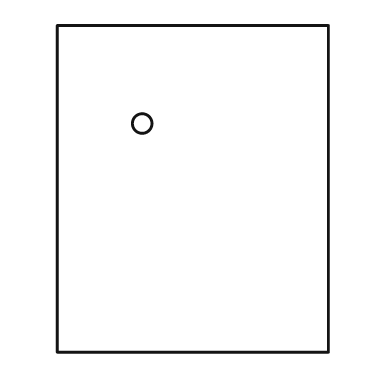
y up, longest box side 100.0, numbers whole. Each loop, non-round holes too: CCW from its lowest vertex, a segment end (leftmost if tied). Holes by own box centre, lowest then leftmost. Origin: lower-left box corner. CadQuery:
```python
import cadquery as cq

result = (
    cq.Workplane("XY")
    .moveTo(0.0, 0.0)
    .lineTo(83.0, 0.0)
    .lineTo(83.0, 100.0)
    .lineTo(0.0, 100.0)
    .close()
    .moveTo(26.0, 70.0)
    .circle(3.0)
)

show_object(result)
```